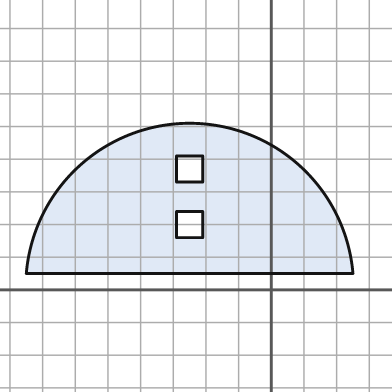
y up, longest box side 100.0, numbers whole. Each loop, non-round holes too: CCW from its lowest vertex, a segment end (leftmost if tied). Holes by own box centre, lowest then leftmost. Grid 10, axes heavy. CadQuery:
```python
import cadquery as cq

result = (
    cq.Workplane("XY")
    .moveTo(-75.0, 5.0)
    .lineTo(25.0, 5.0)
    .threePointArc((-25.0, 51.0), (-75.0, 5.0))
    .close()
    .moveTo(-29.0, 16.0)
    .lineTo(-21.0, 16.0)
    .lineTo(-21.0, 24.0)
    .lineTo(-29.0, 24.0)
    .close()
    .moveTo(-29.0, 33.0)
    .lineTo(-21.0, 33.0)
    .lineTo(-21.0, 41.0)
    .lineTo(-29.0, 41.0)
    .close()
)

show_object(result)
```